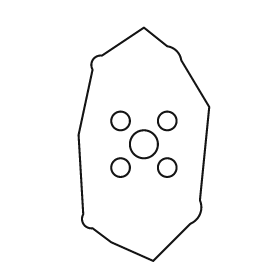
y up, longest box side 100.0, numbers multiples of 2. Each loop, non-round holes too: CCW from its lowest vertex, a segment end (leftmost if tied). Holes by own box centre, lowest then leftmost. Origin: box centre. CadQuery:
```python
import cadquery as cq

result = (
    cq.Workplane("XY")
    .moveTo(4.0, -50.0)
    .lineTo(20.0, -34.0)
    .threePointArc((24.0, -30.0), (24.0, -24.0))
    .lineTo(28.0, 16.0)
    .lineTo(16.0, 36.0)
    .threePointArc((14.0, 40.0), (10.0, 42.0))
    .lineTo(0.0, 50.0)
    .lineTo(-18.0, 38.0)
    .threePointArc((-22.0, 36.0), (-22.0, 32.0))
    .lineTo(-28.0, 4.0)
    .lineTo(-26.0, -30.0)
    .threePointArc((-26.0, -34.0), (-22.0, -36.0))
    .lineTo(-14.0, -42.0)
    .close()
    .moveTo(-10.0, -10.0)
    .circle(4.0)
    .moveTo(10.0, -10.0)
    .circle(4.0)
    .moveTo(0.0, 0.0)
    .circle(6.0)
    .moveTo(-10.0, 10.0)
    .circle(4.0)
    .moveTo(10.0, 10.0)
    .circle(4.0)
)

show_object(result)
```